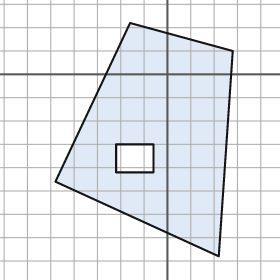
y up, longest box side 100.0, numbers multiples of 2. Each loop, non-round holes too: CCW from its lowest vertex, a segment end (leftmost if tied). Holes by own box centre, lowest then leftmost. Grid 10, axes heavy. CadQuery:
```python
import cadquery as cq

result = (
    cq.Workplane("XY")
    .moveTo(22.0, -78.0)
    .lineTo(28.0, 10.0)
    .lineTo(-16.0, 22.0)
    .lineTo(-48.0, -46.0)
    .close()
    .moveTo(-22.0, -42.0)
    .lineTo(-6.0, -42.0)
    .lineTo(-6.0, -30.0)
    .lineTo(-22.0, -30.0)
    .close()
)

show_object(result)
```